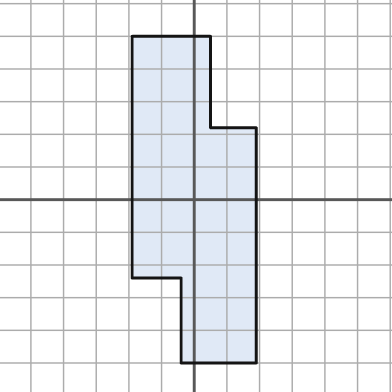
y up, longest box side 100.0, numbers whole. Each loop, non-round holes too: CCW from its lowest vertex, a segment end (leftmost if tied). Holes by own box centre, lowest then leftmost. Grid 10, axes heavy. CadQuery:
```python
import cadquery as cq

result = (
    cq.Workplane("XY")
    .moveTo(-4.0, -50.0)
    .lineTo(19.0, -50.0)
    .lineTo(19.0, 22.0)
    .lineTo(5.0, 22.0)
    .lineTo(5.0, 50.0)
    .lineTo(-19.0, 50.0)
    .lineTo(-19.0, -24.0)
    .lineTo(-4.0, -24.0)
    .close()
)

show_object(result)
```